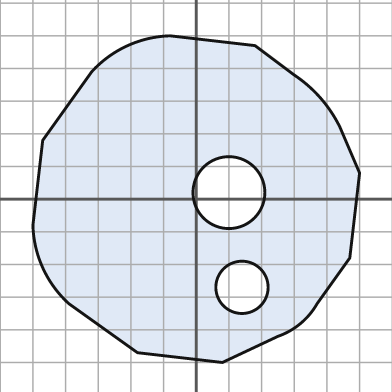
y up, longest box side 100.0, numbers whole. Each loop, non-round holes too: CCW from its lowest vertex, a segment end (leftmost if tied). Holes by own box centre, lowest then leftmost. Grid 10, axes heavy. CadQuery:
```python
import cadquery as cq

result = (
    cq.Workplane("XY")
    .moveTo(8.0, -50.0)
    .lineTo(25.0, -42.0)
    .threePointArc((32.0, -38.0), (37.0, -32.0))
    .lineTo(47.0, -18.0)
    .lineTo(50.0, 8.0)
    .lineTo(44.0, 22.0)
    .threePointArc((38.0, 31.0), (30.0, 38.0))
    .lineTo(18.0, 47.0)
    .lineTo(-8.0, 50.0)
    .threePointArc((-21.0, 47.0), (-32.0, 39.0))
    .lineTo(-47.0, 18.0)
    .lineTo(-50.0, -8.0)
    .threePointArc((-47.0, -21.0), (-39.0, -32.0))
    .lineTo(-18.0, -47.0)
    .close()
    .moveTo(14.0, -27.0)
    .circle(8.0)
    .moveTo(10.0, 2.0)
    .circle(11.0)
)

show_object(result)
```